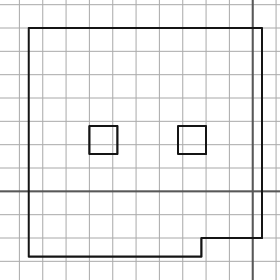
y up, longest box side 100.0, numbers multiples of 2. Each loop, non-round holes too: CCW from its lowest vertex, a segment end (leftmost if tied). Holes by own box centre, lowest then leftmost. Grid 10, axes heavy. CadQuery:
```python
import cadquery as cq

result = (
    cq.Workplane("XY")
    .moveTo(-96.0, -28.0)
    .lineTo(-22.0, -28.0)
    .lineTo(-22.0, -20.0)
    .lineTo(4.0, -20.0)
    .lineTo(4.0, 70.0)
    .lineTo(-96.0, 70.0)
    .close()
    .moveTo(-70.0, 16.0)
    .lineTo(-58.0, 16.0)
    .lineTo(-58.0, 28.0)
    .lineTo(-70.0, 28.0)
    .close()
    .moveTo(-32.0, 16.0)
    .lineTo(-20.0, 16.0)
    .lineTo(-20.0, 28.0)
    .lineTo(-32.0, 28.0)
    .close()
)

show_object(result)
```